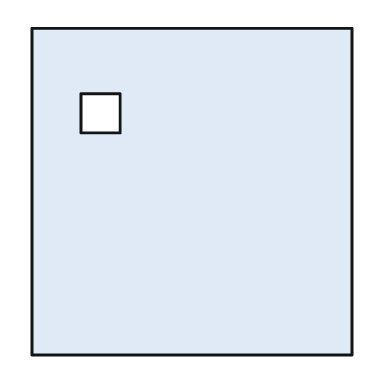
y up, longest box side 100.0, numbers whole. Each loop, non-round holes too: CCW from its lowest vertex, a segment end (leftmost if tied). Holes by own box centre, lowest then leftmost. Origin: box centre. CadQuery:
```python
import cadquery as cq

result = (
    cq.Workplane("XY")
    .moveTo(-49.0, -50.0)
    .lineTo(49.0, -50.0)
    .lineTo(49.0, 50.0)
    .lineTo(-49.0, 50.0)
    .close()
    .moveTo(-34.0, 18.0)
    .lineTo(-22.0, 18.0)
    .lineTo(-22.0, 30.0)
    .lineTo(-34.0, 30.0)
    .close()
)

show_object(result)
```